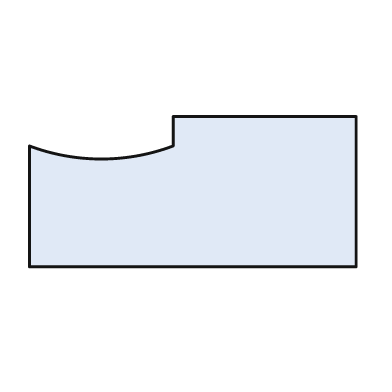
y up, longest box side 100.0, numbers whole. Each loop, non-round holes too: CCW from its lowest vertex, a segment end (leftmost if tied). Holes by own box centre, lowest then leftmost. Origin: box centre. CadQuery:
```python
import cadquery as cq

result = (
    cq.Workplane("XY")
    .moveTo(-50.0, -23.0)
    .lineTo(50.0, -23.0)
    .lineTo(50.0, 23.0)
    .lineTo(-6.0, 23.0)
    .lineTo(-6.0, 14.0)
    .threePointArc((-28.0, 10.0), (-50.0, 14.0))
    .close()
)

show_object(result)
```